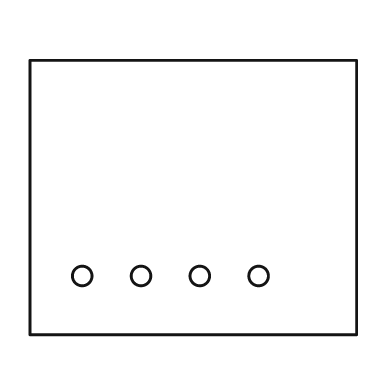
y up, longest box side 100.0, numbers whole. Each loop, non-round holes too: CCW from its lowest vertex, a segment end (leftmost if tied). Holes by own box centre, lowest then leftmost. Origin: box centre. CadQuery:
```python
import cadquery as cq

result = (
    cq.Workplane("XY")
    .moveTo(-50.0, -42.0)
    .lineTo(50.0, -42.0)
    .lineTo(50.0, 42.0)
    .lineTo(-50.0, 42.0)
    .close()
    .moveTo(-34.0, -24.0)
    .circle(3.0)
    .moveTo(-16.0, -24.0)
    .circle(3.0)
    .moveTo(2.0, -24.0)
    .circle(3.0)
    .moveTo(20.0, -24.0)
    .circle(3.0)
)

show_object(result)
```